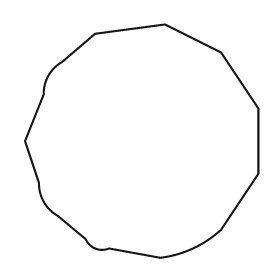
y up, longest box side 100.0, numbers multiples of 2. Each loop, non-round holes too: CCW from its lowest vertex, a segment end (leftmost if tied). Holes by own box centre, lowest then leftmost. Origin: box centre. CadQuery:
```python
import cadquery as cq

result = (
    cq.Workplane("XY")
    .moveTo(8.0, -50.0)
    .threePointArc((22.0, -46.0), (34.0, -38.0))
    .lineTo(50.0, -14.0)
    .lineTo(50.0, 14.0)
    .lineTo(34.0, 38.0)
    .lineTo(10.0, 50.0)
    .lineTo(-20.0, 46.0)
    .lineTo(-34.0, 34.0)
    .threePointArc((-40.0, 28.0), (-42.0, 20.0))
    .lineTo(-50.0, 0.0)
    .lineTo(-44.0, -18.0)
    .threePointArc((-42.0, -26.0), (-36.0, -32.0))
    .lineTo(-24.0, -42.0)
    .threePointArc((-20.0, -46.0), (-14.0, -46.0))
    .close()
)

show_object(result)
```